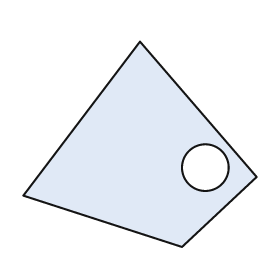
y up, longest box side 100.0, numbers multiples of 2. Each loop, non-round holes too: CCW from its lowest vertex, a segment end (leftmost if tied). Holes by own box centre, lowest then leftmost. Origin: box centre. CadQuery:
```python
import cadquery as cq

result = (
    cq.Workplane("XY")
    .moveTo(18.0, -44.0)
    .lineTo(50.0, -14.0)
    .lineTo(0.0, 44.0)
    .lineTo(-50.0, -22.0)
    .close()
    .moveTo(28.0, -10.0)
    .circle(10.0)
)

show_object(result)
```